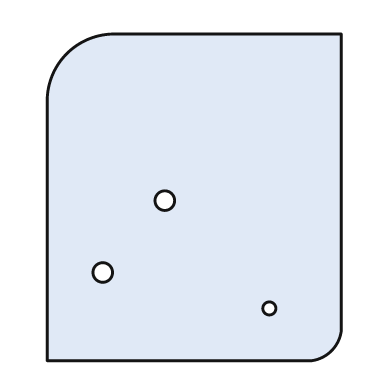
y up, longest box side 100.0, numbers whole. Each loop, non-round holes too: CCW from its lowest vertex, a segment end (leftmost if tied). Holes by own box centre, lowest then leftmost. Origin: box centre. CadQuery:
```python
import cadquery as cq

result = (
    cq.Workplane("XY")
    .moveTo(-45.0, -50.0)
    .lineTo(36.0, -50.0)
    .threePointArc((42.0, -47.0), (45.0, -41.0))
    .lineTo(45.0, 50.0)
    .lineTo(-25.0, 50.0)
    .threePointArc((-39.0, 44.0), (-45.0, 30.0))
    .close()
    .moveTo(23.0, -34.0)
    .circle(2.0)
    .moveTo(-28.0, -23.0)
    .circle(3.0)
    .moveTo(-9.0, -1.0)
    .circle(3.0)
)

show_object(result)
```